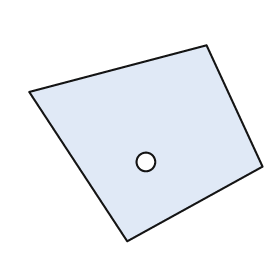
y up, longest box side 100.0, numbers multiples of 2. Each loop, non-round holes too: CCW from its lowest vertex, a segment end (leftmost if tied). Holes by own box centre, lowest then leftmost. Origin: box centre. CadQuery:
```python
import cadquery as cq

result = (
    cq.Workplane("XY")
    .moveTo(-8.0, -42.0)
    .lineTo(50.0, -10.0)
    .lineTo(26.0, 42.0)
    .lineTo(-50.0, 22.0)
    .close()
    .moveTo(0.0, -8.0)
    .circle(4.0)
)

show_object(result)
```